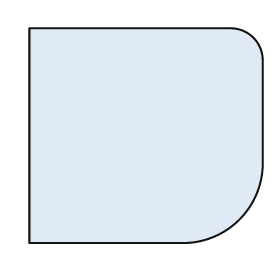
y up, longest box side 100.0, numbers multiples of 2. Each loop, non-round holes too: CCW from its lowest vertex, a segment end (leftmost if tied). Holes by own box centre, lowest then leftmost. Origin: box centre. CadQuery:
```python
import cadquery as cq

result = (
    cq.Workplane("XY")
    .moveTo(-50.0, -46.0)
    .lineTo(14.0, -46.0)
    .threePointArc((40.0, -36.0), (50.0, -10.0))
    .lineTo(50.0, 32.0)
    .threePointArc((46.0, 42.0), (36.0, 46.0))
    .lineTo(-50.0, 46.0)
    .close()
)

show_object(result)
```